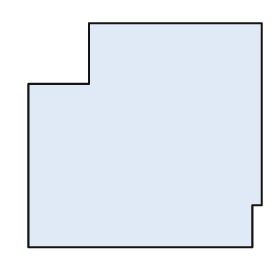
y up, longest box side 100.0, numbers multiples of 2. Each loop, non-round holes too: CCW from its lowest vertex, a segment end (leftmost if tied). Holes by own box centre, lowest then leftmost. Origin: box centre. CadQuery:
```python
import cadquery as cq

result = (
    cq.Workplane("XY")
    .moveTo(-50.0, -48.0)
    .lineTo(46.0, -48.0)
    .lineTo(46.0, -30.0)
    .lineTo(50.0, -30.0)
    .lineTo(50.0, 48.0)
    .lineTo(-24.0, 48.0)
    .lineTo(-24.0, 22.0)
    .lineTo(-50.0, 22.0)
    .close()
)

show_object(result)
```